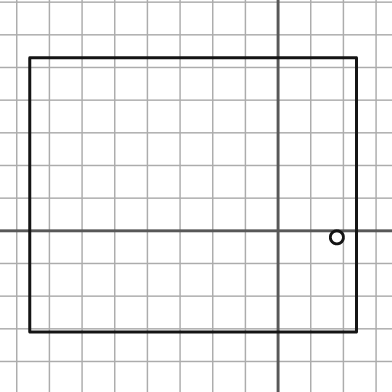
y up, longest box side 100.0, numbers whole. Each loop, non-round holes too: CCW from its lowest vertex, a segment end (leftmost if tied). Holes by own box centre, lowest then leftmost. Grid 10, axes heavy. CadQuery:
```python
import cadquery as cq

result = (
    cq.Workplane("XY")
    .moveTo(-76.0, -31.0)
    .lineTo(24.0, -31.0)
    .lineTo(24.0, 53.0)
    .lineTo(-76.0, 53.0)
    .close()
    .moveTo(18.0, -2.0)
    .circle(2.0)
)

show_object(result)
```